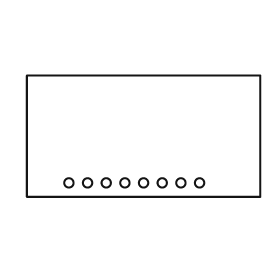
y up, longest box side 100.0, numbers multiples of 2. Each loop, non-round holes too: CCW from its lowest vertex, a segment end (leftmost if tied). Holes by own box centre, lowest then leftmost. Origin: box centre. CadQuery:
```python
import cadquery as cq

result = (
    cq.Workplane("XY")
    .moveTo(-50.0, -26.0)
    .lineTo(50.0, -26.0)
    .lineTo(50.0, 26.0)
    .lineTo(-50.0, 26.0)
    .close()
    .moveTo(-32.0, -20.0)
    .circle(2.0)
    .moveTo(-24.0, -20.0)
    .circle(2.0)
    .moveTo(-16.0, -20.0)
    .circle(2.0)
    .moveTo(-8.0, -20.0)
    .circle(2.0)
    .moveTo(0.0, -20.0)
    .circle(2.0)
    .moveTo(8.0, -20.0)
    .circle(2.0)
    .moveTo(16.0, -20.0)
    .circle(2.0)
    .moveTo(24.0, -20.0)
    .circle(2.0)
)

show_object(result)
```